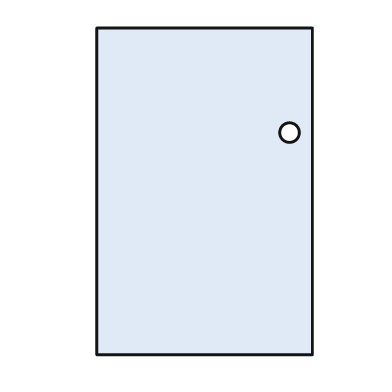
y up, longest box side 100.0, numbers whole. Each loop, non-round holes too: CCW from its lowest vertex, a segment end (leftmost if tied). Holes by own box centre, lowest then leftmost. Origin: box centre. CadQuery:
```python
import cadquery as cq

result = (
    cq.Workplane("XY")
    .moveTo(-33.0, -50.0)
    .lineTo(33.0, -50.0)
    .lineTo(33.0, 50.0)
    .lineTo(-33.0, 50.0)
    .close()
    .moveTo(26.0, 18.0)
    .circle(3.0)
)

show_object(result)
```